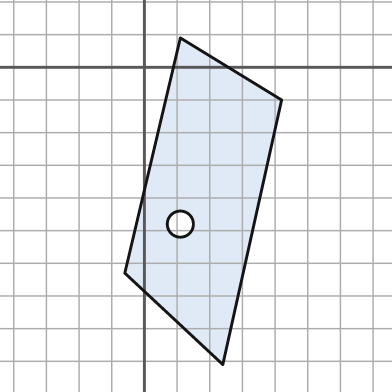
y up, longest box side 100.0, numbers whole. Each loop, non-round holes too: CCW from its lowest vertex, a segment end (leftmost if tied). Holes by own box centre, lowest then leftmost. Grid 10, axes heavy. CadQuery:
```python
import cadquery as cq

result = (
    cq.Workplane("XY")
    .moveTo(24.0, -91.0)
    .lineTo(42.0, -10.0)
    .lineTo(11.0, 9.0)
    .lineTo(-6.0, -63.0)
    .close()
    .moveTo(11.0, -48.0)
    .circle(4.0)
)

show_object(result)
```